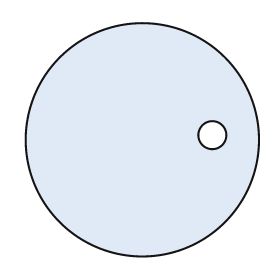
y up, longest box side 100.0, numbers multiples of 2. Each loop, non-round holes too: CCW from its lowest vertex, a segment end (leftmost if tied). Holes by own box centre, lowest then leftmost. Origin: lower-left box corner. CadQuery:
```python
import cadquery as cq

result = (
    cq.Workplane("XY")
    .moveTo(50.0, 50.0)
    .circle(50.0)
    .moveTo(80.0, 52.0)
    .circle(6.0)
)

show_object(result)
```